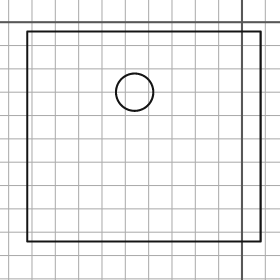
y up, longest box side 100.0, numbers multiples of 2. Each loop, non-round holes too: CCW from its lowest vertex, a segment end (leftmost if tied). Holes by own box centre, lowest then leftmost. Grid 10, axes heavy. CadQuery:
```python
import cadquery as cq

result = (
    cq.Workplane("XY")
    .moveTo(-92.0, -94.0)
    .lineTo(8.0, -94.0)
    .lineTo(8.0, -4.0)
    .lineTo(-92.0, -4.0)
    .close()
    .moveTo(-46.0, -30.0)
    .circle(8.0)
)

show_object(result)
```